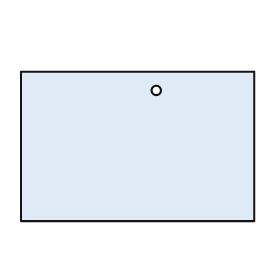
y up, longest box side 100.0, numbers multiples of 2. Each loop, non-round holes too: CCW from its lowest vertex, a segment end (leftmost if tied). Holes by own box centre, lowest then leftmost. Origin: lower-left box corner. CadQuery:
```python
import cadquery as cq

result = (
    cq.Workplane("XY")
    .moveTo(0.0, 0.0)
    .lineTo(100.0, 0.0)
    .lineTo(100.0, 64.0)
    .lineTo(0.0, 64.0)
    .close()
    .moveTo(58.0, 56.0)
    .circle(2.0)
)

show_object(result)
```